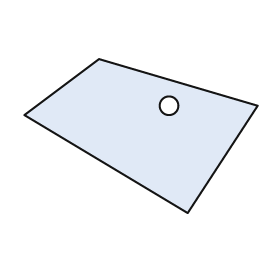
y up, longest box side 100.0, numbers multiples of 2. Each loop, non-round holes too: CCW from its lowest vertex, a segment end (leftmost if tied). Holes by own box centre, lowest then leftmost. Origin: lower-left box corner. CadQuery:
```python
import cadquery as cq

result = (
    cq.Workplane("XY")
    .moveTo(70.0, 0.0)
    .lineTo(100.0, 46.0)
    .lineTo(32.0, 66.0)
    .lineTo(0.0, 42.0)
    .close()
    .moveTo(62.0, 46.0)
    .circle(4.0)
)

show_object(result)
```